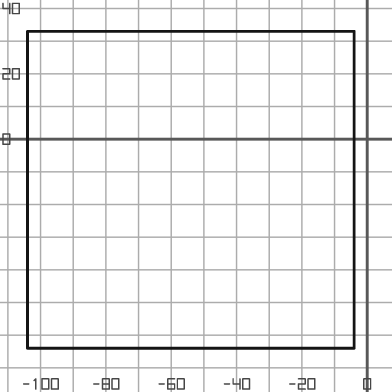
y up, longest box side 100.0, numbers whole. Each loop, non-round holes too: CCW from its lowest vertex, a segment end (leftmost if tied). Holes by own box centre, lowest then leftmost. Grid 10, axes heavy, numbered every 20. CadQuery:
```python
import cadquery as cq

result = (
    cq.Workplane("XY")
    .moveTo(-104.0, -64.0)
    .lineTo(-4.0, -64.0)
    .lineTo(-4.0, 33.0)
    .lineTo(-104.0, 33.0)
    .close()
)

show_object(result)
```